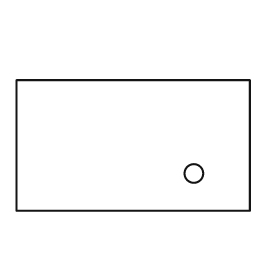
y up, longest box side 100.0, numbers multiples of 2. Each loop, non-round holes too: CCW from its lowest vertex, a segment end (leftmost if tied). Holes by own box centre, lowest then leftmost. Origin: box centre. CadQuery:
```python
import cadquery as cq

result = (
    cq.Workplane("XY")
    .moveTo(-50.0, -28.0)
    .lineTo(50.0, -28.0)
    .lineTo(50.0, 28.0)
    .lineTo(-50.0, 28.0)
    .close()
    .moveTo(26.0, -12.0)
    .circle(4.0)
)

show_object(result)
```